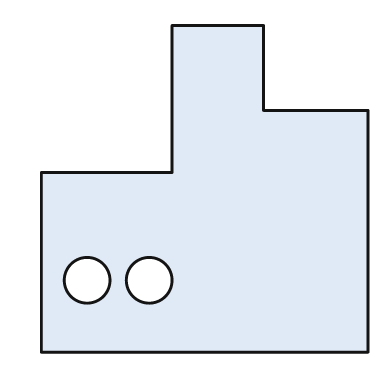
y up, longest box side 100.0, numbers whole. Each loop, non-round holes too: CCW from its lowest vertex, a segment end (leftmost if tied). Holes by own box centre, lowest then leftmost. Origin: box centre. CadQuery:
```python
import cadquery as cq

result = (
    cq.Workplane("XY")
    .moveTo(-50.0, -50.0)
    .lineTo(50.0, -50.0)
    .lineTo(50.0, 24.0)
    .lineTo(18.0, 24.0)
    .lineTo(18.0, 50.0)
    .lineTo(-10.0, 50.0)
    .lineTo(-10.0, 5.0)
    .lineTo(-50.0, 5.0)
    .close()
    .moveTo(-36.0, -28.0)
    .circle(7.0)
    .moveTo(-17.0, -28.0)
    .circle(7.0)
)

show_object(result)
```